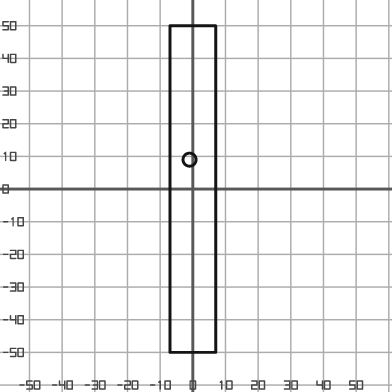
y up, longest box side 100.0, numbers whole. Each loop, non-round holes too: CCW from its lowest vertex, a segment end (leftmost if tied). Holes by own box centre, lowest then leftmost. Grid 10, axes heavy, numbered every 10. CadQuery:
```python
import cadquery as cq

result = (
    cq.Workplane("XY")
    .moveTo(-7.0, -50.0)
    .lineTo(7.0, -50.0)
    .lineTo(7.0, 50.0)
    .lineTo(-7.0, 50.0)
    .close()
    .moveTo(-1.0, 9.0)
    .circle(2.0)
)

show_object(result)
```